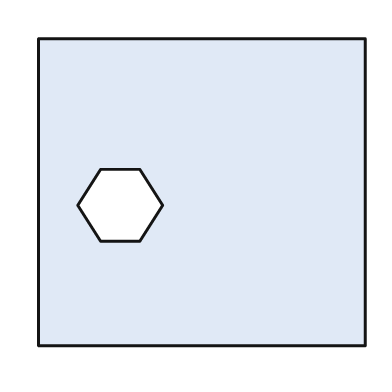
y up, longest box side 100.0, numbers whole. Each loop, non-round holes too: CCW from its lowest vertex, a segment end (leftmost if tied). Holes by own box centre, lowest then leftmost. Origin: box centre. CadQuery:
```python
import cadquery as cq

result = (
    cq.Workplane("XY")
    .moveTo(-50.0, -47.0)
    .lineTo(50.0, -47.0)
    .lineTo(50.0, 47.0)
    .lineTo(-50.0, 47.0)
    .close()
    .moveTo(-31.0, -15.0)
    .lineTo(-19.0, -15.0)
    .lineTo(-12.0, -4.0)
    .lineTo(-19.0, 7.0)
    .lineTo(-31.0, 7.0)
    .lineTo(-38.0, -4.0)
    .close()
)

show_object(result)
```